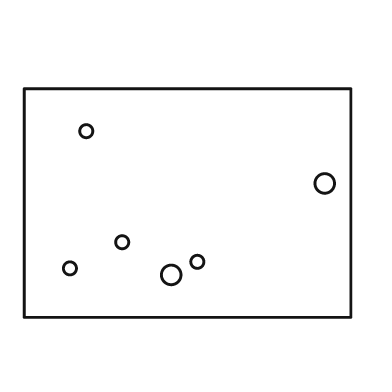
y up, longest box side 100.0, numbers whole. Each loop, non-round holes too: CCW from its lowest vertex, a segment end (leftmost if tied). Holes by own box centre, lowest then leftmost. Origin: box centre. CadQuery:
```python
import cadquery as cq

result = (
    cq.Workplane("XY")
    .moveTo(-50.0, -35.0)
    .lineTo(50.0, -35.0)
    .lineTo(50.0, 35.0)
    .lineTo(-50.0, 35.0)
    .close()
    .moveTo(-5.0, -22.0)
    .circle(3.0)
    .moveTo(-36.0, -20.0)
    .circle(2.0)
    .moveTo(3.0, -18.0)
    .circle(2.0)
    .moveTo(-20.0, -12.0)
    .circle(2.0)
    .moveTo(42.0, 6.0)
    .circle(3.0)
    .moveTo(-31.0, 22.0)
    .circle(2.0)
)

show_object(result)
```